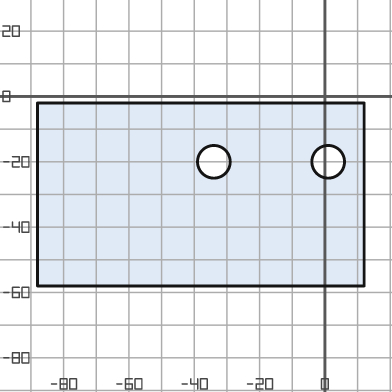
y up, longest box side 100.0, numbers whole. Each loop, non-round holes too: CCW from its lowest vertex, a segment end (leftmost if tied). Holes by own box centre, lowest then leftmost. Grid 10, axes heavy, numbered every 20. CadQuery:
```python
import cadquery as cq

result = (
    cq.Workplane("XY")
    .moveTo(-88.0, -58.0)
    .lineTo(12.0, -58.0)
    .lineTo(12.0, -2.0)
    .lineTo(-88.0, -2.0)
    .close()
    .moveTo(-34.0, -20.0)
    .circle(5.0)
    .moveTo(1.0, -20.0)
    .circle(5.0)
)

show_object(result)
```